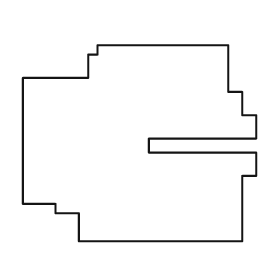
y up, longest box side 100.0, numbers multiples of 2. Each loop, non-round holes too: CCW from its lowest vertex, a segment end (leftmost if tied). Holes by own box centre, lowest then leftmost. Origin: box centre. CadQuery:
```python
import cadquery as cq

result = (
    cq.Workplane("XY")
    .moveTo(-26.0, -42.0)
    .lineTo(44.0, -42.0)
    .lineTo(44.0, -14.0)
    .lineTo(50.0, -14.0)
    .lineTo(50.0, -4.0)
    .lineTo(4.0, -4.0)
    .lineTo(4.0, 2.0)
    .lineTo(50.0, 2.0)
    .lineTo(50.0, 12.0)
    .lineTo(44.0, 12.0)
    .lineTo(44.0, 22.0)
    .lineTo(38.0, 22.0)
    .lineTo(38.0, 42.0)
    .lineTo(-18.0, 42.0)
    .lineTo(-18.0, 38.0)
    .lineTo(-22.0, 38.0)
    .lineTo(-22.0, 28.0)
    .lineTo(-50.0, 28.0)
    .lineTo(-50.0, -26.0)
    .lineTo(-36.0, -26.0)
    .lineTo(-36.0, -30.0)
    .lineTo(-26.0, -30.0)
    .close()
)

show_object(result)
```